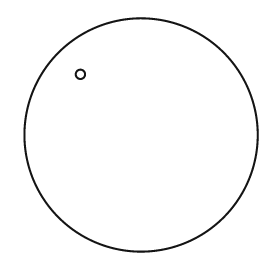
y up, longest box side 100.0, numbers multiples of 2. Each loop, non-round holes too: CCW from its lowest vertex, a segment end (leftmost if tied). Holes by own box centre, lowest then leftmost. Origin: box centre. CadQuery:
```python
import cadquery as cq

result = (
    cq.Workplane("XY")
    .moveTo(0.0, 0.0)
    .circle(50.0)
    .moveTo(-26.0, 26.0)
    .circle(2.0)
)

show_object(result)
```